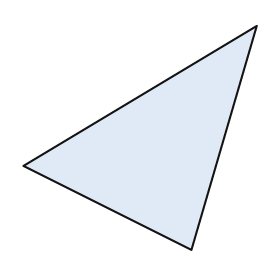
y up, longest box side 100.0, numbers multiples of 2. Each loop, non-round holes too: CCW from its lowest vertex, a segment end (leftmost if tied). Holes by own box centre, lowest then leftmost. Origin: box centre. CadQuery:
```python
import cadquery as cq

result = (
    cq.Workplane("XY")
    .moveTo(22.0, -48.0)
    .lineTo(50.0, 48.0)
    .lineTo(-50.0, -12.0)
    .close()
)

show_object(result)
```